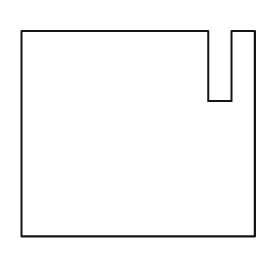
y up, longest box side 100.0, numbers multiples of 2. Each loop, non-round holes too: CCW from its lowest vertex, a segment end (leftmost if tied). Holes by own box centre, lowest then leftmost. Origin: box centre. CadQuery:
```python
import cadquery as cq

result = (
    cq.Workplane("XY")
    .moveTo(-50.0, -44.0)
    .lineTo(50.0, -44.0)
    .lineTo(50.0, 44.0)
    .lineTo(40.0, 44.0)
    .lineTo(40.0, 14.0)
    .lineTo(30.0, 14.0)
    .lineTo(30.0, 44.0)
    .lineTo(-50.0, 44.0)
    .close()
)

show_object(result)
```